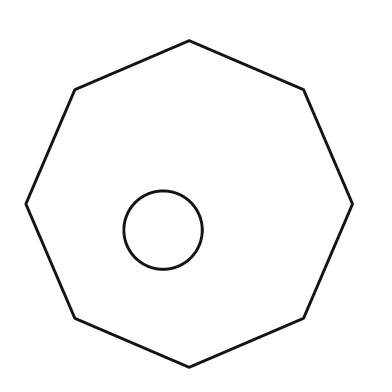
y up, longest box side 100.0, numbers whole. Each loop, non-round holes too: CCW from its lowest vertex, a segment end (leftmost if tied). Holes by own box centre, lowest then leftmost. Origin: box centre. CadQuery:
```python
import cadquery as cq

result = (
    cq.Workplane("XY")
    .moveTo(0.0, -50.0)
    .lineTo(35.0, -35.0)
    .lineTo(50.0, 0.0)
    .lineTo(35.0, 35.0)
    .lineTo(0.0, 50.0)
    .lineTo(-35.0, 35.0)
    .lineTo(-50.0, 0.0)
    .lineTo(-35.0, -35.0)
    .close()
    .moveTo(-8.0, -8.0)
    .circle(12.0)
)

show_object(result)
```